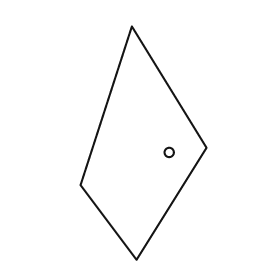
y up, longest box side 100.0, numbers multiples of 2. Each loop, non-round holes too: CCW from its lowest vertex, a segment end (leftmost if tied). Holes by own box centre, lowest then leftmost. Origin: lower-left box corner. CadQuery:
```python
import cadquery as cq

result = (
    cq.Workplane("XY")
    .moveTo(24.0, 0.0)
    .lineTo(54.0, 48.0)
    .lineTo(22.0, 100.0)
    .lineTo(0.0, 32.0)
    .close()
    .moveTo(38.0, 46.0)
    .circle(2.0)
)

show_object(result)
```